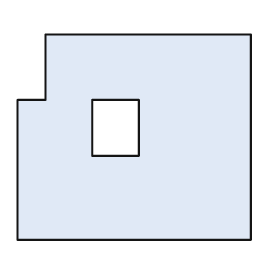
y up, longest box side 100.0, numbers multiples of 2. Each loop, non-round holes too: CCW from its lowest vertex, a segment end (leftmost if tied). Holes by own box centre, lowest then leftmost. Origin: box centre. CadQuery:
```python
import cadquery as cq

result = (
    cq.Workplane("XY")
    .moveTo(-50.0, -44.0)
    .lineTo(50.0, -44.0)
    .lineTo(50.0, 44.0)
    .lineTo(-38.0, 44.0)
    .lineTo(-38.0, 16.0)
    .lineTo(-50.0, 16.0)
    .close()
    .moveTo(-18.0, -8.0)
    .lineTo(2.0, -8.0)
    .lineTo(2.0, 16.0)
    .lineTo(-18.0, 16.0)
    .close()
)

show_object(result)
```